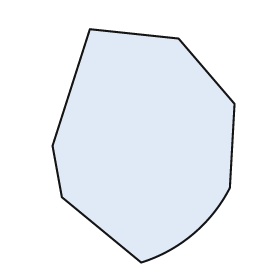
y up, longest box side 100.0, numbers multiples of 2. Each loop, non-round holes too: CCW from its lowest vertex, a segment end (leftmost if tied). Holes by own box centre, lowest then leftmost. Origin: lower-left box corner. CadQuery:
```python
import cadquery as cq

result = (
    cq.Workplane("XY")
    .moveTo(38.0, 0.0)
    .threePointArc((60.0, 12.0), (76.0, 32.0))
    .lineTo(78.0, 68.0)
    .lineTo(54.0, 96.0)
    .lineTo(16.0, 100.0)
    .lineTo(0.0, 50.0)
    .lineTo(4.0, 28.0)
    .close()
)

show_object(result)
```